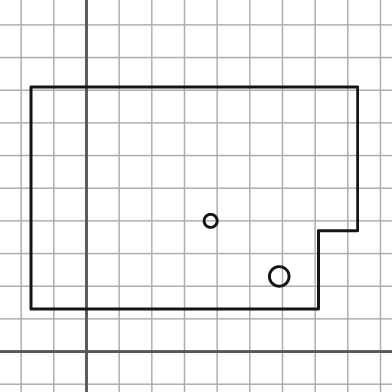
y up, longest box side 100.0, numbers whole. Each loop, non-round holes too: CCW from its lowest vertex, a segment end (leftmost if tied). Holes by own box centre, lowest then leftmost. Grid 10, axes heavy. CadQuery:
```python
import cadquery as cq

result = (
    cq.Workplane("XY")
    .moveTo(-17.0, 13.0)
    .lineTo(71.0, 13.0)
    .lineTo(71.0, 37.0)
    .lineTo(83.0, 37.0)
    .lineTo(83.0, 81.0)
    .lineTo(-17.0, 81.0)
    .close()
    .moveTo(59.0, 23.0)
    .circle(3.0)
    .moveTo(38.0, 40.0)
    .circle(2.0)
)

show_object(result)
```